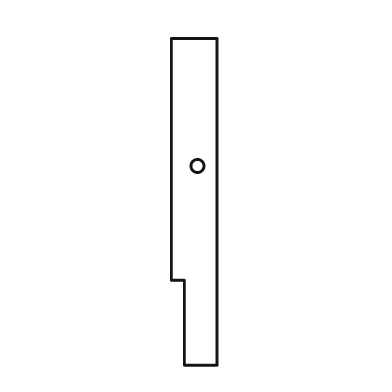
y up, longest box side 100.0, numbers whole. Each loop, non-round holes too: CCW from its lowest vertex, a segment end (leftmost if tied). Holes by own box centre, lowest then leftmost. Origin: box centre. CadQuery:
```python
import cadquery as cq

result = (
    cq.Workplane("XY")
    .moveTo(-3.0, -50.0)
    .lineTo(7.0, -50.0)
    .lineTo(7.0, 50.0)
    .lineTo(-7.0, 50.0)
    .lineTo(-7.0, -24.0)
    .lineTo(-3.0, -24.0)
    .close()
    .moveTo(1.0, 11.0)
    .circle(2.0)
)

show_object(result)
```